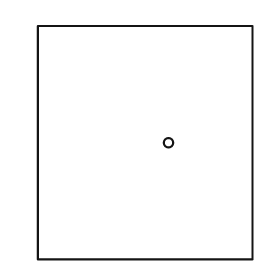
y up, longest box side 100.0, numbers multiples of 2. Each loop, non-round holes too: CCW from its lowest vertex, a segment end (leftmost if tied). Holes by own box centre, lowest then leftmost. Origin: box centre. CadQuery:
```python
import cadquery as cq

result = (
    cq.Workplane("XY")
    .moveTo(-46.0, -50.0)
    .lineTo(46.0, -50.0)
    .lineTo(46.0, 50.0)
    .lineTo(-46.0, 50.0)
    .close()
    .moveTo(10.0, 0.0)
    .circle(2.0)
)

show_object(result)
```